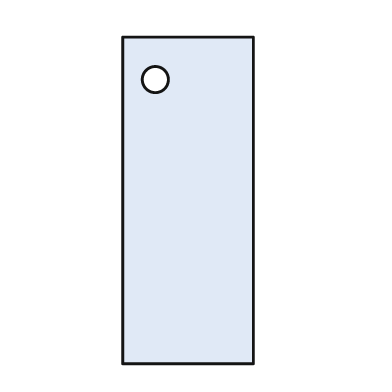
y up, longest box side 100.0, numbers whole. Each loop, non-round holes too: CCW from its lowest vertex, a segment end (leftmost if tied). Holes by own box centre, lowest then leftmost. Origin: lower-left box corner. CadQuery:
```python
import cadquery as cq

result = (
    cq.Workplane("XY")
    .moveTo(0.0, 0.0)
    .lineTo(40.0, 0.0)
    .lineTo(40.0, 100.0)
    .lineTo(0.0, 100.0)
    .close()
    .moveTo(10.0, 87.0)
    .circle(4.0)
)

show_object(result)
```